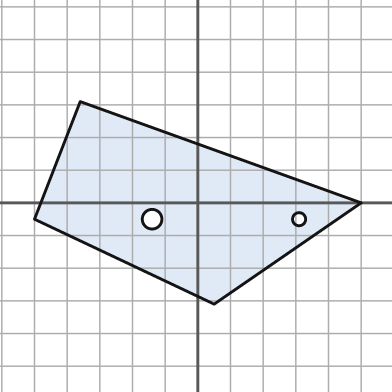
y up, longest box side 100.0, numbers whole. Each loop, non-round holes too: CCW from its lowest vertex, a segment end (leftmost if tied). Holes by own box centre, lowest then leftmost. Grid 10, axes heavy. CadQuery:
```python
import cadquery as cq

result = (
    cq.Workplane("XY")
    .moveTo(5.0, -31.0)
    .lineTo(50.0, 0.0)
    .lineTo(-36.0, 31.0)
    .lineTo(-50.0, -5.0)
    .close()
    .moveTo(-14.0, -5.0)
    .circle(3.0)
    .moveTo(31.0, -5.0)
    .circle(2.0)
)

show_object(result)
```